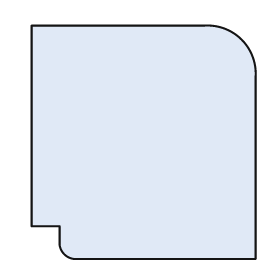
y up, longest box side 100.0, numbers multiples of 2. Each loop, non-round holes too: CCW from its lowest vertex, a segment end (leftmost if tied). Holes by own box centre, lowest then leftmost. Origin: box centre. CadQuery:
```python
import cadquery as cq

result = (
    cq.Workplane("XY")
    .moveTo(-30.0, -50.0)
    .lineTo(48.0, -50.0)
    .lineTo(48.0, 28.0)
    .threePointArc((42.0, 44.0), (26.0, 50.0))
    .lineTo(-48.0, 50.0)
    .lineTo(-48.0, -36.0)
    .lineTo(-36.0, -36.0)
    .lineTo(-36.0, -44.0)
    .threePointArc((-34.0, -48.0), (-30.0, -50.0))
    .close()
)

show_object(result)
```